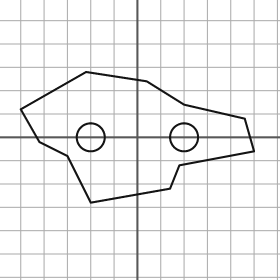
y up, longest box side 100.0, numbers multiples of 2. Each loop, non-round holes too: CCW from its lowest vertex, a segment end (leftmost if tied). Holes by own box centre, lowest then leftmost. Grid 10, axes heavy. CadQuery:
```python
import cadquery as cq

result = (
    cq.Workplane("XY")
    .moveTo(-20.0, -28.0)
    .lineTo(14.0, -22.0)
    .lineTo(18.0, -12.0)
    .lineTo(50.0, -6.0)
    .lineTo(46.0, 8.0)
    .lineTo(20.0, 14.0)
    .lineTo(4.0, 24.0)
    .lineTo(-22.0, 28.0)
    .lineTo(-50.0, 12.0)
    .lineTo(-42.0, -2.0)
    .lineTo(-30.0, -8.0)
    .close()
    .moveTo(-20.0, 0.0)
    .circle(6.0)
    .moveTo(20.0, 0.0)
    .circle(6.0)
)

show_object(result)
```